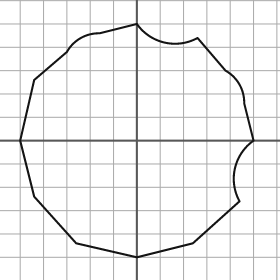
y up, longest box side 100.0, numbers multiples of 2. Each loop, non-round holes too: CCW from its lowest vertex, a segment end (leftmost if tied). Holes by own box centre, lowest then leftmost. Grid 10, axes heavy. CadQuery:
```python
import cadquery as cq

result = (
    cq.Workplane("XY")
    .moveTo(0.0, -50.0)
    .lineTo(24.0, -44.0)
    .lineTo(44.0, -26.0)
    .threePointArc((42.0, -12.0), (50.0, 0.0))
    .lineTo(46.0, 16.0)
    .threePointArc((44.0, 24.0), (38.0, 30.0))
    .lineTo(26.0, 44.0)
    .threePointArc((12.0, 42.0), (0.0, 50.0))
    .lineTo(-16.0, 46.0)
    .threePointArc((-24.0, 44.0), (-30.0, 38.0))
    .lineTo(-44.0, 26.0)
    .lineTo(-50.0, 0.0)
    .lineTo(-44.0, -24.0)
    .lineTo(-26.0, -44.0)
    .close()
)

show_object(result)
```